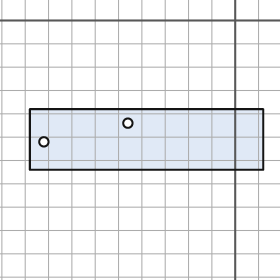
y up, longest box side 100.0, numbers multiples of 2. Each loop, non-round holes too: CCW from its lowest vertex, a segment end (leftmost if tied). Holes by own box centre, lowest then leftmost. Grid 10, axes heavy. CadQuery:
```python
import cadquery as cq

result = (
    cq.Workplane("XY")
    .moveTo(-88.0, -64.0)
    .lineTo(12.0, -64.0)
    .lineTo(12.0, -38.0)
    .lineTo(-88.0, -38.0)
    .close()
    .moveTo(-82.0, -52.0)
    .circle(2.0)
    .moveTo(-46.0, -44.0)
    .circle(2.0)
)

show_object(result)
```